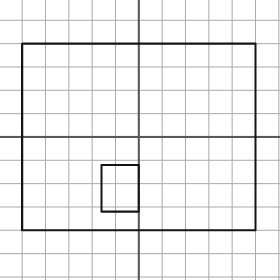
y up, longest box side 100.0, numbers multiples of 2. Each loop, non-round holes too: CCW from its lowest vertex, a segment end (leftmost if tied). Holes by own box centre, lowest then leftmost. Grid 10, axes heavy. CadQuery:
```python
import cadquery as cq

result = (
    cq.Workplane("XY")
    .moveTo(-50.0, -40.0)
    .lineTo(50.0, -40.0)
    .lineTo(50.0, 40.0)
    .lineTo(-50.0, 40.0)
    .close()
    .moveTo(-16.0, -32.0)
    .lineTo(0.0, -32.0)
    .lineTo(0.0, -12.0)
    .lineTo(-16.0, -12.0)
    .close()
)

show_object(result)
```